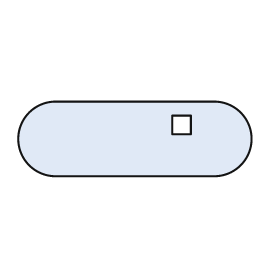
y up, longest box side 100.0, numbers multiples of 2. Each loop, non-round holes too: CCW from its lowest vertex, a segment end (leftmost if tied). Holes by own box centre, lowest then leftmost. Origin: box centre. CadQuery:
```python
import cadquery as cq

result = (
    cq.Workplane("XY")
    .moveTo(-34.0, -16.0)
    .lineTo(34.0, -16.0)
    .threePointArc((50.0, 0.0), (34.0, 16.0))
    .lineTo(-34.0, 16.0)
    .threePointArc((-50.0, 0.0), (-34.0, -16.0))
    .close()
    .moveTo(16.0, 2.0)
    .lineTo(24.0, 2.0)
    .lineTo(24.0, 10.0)
    .lineTo(16.0, 10.0)
    .close()
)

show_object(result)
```